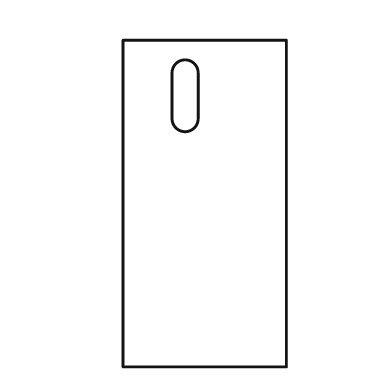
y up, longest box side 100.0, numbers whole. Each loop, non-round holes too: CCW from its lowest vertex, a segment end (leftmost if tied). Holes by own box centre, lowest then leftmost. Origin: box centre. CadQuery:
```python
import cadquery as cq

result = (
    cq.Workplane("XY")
    .moveTo(-25.0, -50.0)
    .lineTo(25.0, -50.0)
    .lineTo(25.0, 50.0)
    .lineTo(-25.0, 50.0)
    .close()
    .moveTo(-10.0, 26.0)
    .threePointArc((-6.0, 22.0), (-2.0, 26.0))
    .lineTo(-2.0, 40.0)
    .threePointArc((-6.0, 44.0), (-10.0, 40.0))
    .close()
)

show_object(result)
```